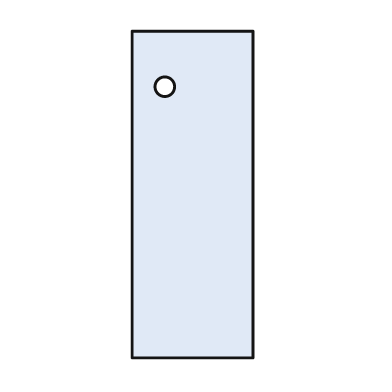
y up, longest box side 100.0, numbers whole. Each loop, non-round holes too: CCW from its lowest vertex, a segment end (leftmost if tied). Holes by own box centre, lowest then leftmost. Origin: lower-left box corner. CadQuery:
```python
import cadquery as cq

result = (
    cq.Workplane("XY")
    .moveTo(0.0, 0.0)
    .lineTo(37.0, 0.0)
    .lineTo(37.0, 100.0)
    .lineTo(0.0, 100.0)
    .close()
    .moveTo(10.0, 83.0)
    .circle(3.0)
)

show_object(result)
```